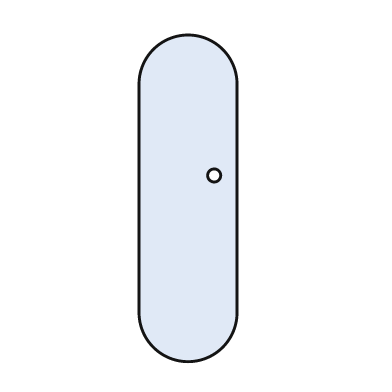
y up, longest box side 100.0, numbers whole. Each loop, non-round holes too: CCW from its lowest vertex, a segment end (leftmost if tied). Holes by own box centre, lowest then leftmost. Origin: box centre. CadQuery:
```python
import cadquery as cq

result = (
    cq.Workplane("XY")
    .moveTo(-15.0, -35.0)
    .threePointArc((0.0, -50.0), (15.0, -35.0))
    .lineTo(15.0, 35.0)
    .threePointArc((0.0, 50.0), (-15.0, 35.0))
    .close()
    .moveTo(8.0, 7.0)
    .circle(2.0)
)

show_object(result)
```